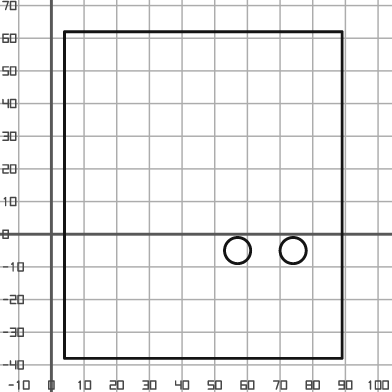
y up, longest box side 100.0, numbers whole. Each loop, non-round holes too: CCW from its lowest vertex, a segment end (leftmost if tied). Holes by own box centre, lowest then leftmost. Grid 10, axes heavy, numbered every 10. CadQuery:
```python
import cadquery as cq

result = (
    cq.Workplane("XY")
    .moveTo(4.0, -38.0)
    .lineTo(89.0, -38.0)
    .lineTo(89.0, 62.0)
    .lineTo(4.0, 62.0)
    .close()
    .moveTo(57.0, -5.0)
    .circle(4.0)
    .moveTo(74.0, -5.0)
    .circle(4.0)
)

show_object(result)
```